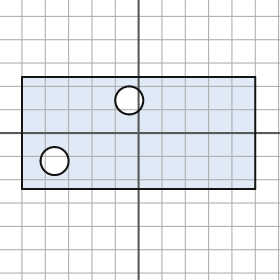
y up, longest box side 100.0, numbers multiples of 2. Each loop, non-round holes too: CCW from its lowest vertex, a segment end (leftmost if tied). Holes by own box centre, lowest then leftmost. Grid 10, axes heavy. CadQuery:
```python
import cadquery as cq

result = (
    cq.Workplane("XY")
    .moveTo(-50.0, -24.0)
    .lineTo(50.0, -24.0)
    .lineTo(50.0, 24.0)
    .lineTo(-50.0, 24.0)
    .close()
    .moveTo(-36.0, -12.0)
    .circle(6.0)
    .moveTo(-4.0, 14.0)
    .circle(6.0)
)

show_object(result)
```